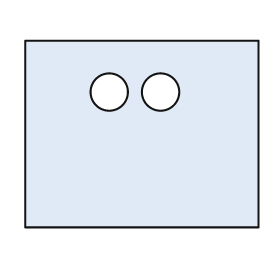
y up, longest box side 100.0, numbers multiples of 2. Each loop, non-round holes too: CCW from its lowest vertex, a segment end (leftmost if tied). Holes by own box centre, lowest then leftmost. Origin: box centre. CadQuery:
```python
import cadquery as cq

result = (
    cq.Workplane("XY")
    .moveTo(-50.0, -40.0)
    .lineTo(50.0, -40.0)
    .lineTo(50.0, 40.0)
    .lineTo(-50.0, 40.0)
    .close()
    .moveTo(-14.0, 18.0)
    .circle(8.0)
    .moveTo(8.0, 18.0)
    .circle(8.0)
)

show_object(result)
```